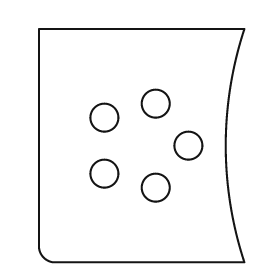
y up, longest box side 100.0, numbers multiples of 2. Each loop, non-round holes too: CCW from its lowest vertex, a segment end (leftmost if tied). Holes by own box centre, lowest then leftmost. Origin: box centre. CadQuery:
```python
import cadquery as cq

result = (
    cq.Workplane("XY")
    .moveTo(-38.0, -50.0)
    .lineTo(44.0, -50.0)
    .threePointArc((36.0, 0.0), (44.0, 50.0))
    .lineTo(-44.0, 50.0)
    .lineTo(-44.0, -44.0)
    .threePointArc((-42.0, -48.0), (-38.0, -50.0))
    .close()
    .moveTo(6.0, -18.0)
    .circle(6.0)
    .moveTo(-16.0, -12.0)
    .circle(6.0)
    .moveTo(20.0, 0.0)
    .circle(6.0)
    .moveTo(-16.0, 12.0)
    .circle(6.0)
    .moveTo(6.0, 18.0)
    .circle(6.0)
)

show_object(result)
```